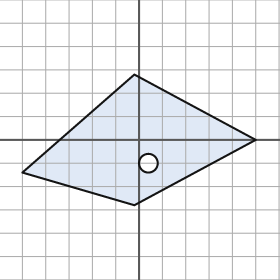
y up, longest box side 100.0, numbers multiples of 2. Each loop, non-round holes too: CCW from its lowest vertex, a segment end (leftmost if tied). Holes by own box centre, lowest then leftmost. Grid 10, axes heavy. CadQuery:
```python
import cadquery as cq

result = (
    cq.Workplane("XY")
    .moveTo(-2.0, -28.0)
    .lineTo(50.0, 0.0)
    .lineTo(-2.0, 28.0)
    .lineTo(-50.0, -14.0)
    .close()
    .moveTo(4.0, -10.0)
    .circle(4.0)
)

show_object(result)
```